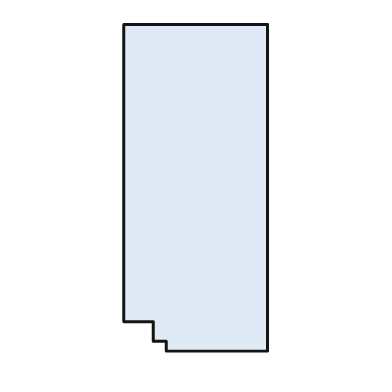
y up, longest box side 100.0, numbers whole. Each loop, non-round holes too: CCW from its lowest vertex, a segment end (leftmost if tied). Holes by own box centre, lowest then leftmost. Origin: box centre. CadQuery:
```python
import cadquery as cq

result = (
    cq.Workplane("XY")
    .moveTo(-9.0, -50.0)
    .lineTo(22.0, -50.0)
    .lineTo(22.0, 50.0)
    .lineTo(-22.0, 50.0)
    .lineTo(-22.0, -41.0)
    .lineTo(-13.0, -41.0)
    .lineTo(-13.0, -47.0)
    .lineTo(-9.0, -47.0)
    .close()
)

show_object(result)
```